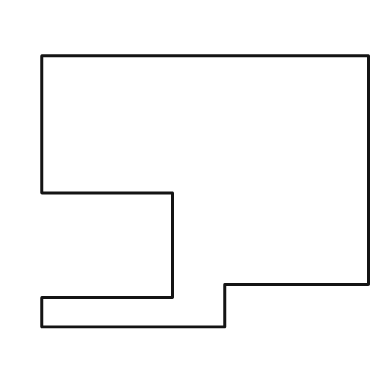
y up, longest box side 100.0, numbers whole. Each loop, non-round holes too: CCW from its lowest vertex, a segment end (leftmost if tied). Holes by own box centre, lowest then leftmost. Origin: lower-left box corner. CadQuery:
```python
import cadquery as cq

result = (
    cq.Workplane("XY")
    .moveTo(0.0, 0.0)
    .lineTo(56.0, 0.0)
    .lineTo(56.0, 13.0)
    .lineTo(100.0, 13.0)
    .lineTo(100.0, 83.0)
    .lineTo(0.0, 83.0)
    .lineTo(0.0, 41.0)
    .lineTo(40.0, 41.0)
    .lineTo(40.0, 9.0)
    .lineTo(0.0, 9.0)
    .close()
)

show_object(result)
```